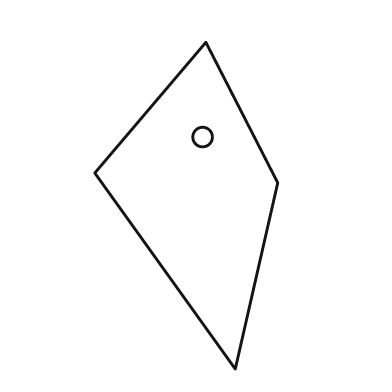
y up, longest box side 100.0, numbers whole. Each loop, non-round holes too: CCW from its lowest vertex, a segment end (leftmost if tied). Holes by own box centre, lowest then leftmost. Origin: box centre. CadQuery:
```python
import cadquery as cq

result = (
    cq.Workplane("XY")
    .moveTo(15.0, -50.0)
    .lineTo(28.0, 7.0)
    .lineTo(6.0, 50.0)
    .lineTo(-28.0, 10.0)
    .close()
    .moveTo(5.0, 21.0)
    .circle(3.0)
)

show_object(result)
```